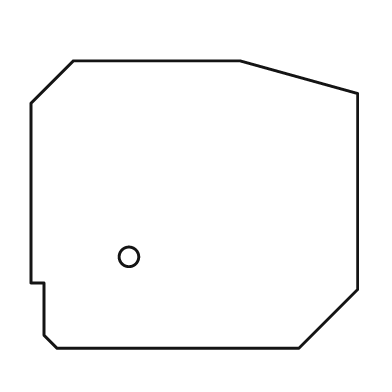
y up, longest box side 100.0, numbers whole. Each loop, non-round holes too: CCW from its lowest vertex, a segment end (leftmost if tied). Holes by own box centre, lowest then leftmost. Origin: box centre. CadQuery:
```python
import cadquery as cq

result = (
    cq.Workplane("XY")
    .moveTo(-42.0, -44.0)
    .lineTo(32.0, -44.0)
    .lineTo(50.0, -26.0)
    .lineTo(50.0, 34.0)
    .lineTo(14.0, 44.0)
    .lineTo(-37.0, 44.0)
    .lineTo(-50.0, 31.0)
    .lineTo(-50.0, -24.0)
    .lineTo(-46.0, -24.0)
    .lineTo(-46.0, -40.0)
    .close()
    .moveTo(-20.0, -16.0)
    .circle(3.0)
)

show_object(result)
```